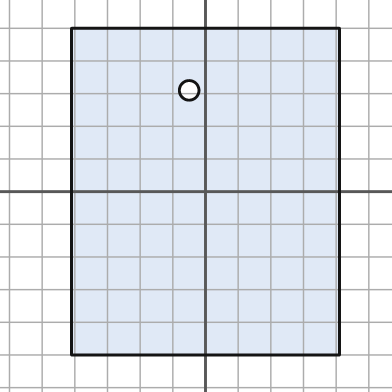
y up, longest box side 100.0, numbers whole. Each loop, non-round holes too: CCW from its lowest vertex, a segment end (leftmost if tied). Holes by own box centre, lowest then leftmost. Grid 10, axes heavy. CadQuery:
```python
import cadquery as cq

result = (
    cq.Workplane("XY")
    .moveTo(-41.0, -50.0)
    .lineTo(41.0, -50.0)
    .lineTo(41.0, 50.0)
    .lineTo(-41.0, 50.0)
    .close()
    .moveTo(-5.0, 31.0)
    .circle(3.0)
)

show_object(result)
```